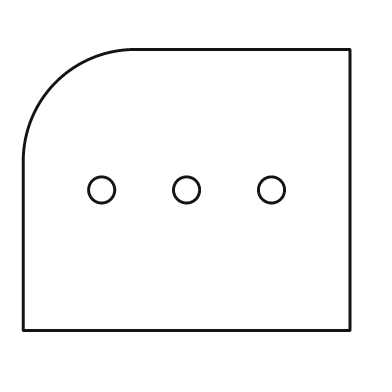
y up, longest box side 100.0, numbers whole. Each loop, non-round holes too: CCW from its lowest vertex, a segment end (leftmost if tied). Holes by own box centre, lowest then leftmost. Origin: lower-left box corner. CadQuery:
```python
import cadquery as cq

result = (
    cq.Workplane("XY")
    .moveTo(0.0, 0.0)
    .lineTo(100.0, 0.0)
    .lineTo(100.0, 86.0)
    .lineTo(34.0, 86.0)
    .threePointArc((10.0, 76.0), (0.0, 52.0))
    .close()
    .moveTo(24.0, 43.0)
    .circle(4.0)
    .moveTo(50.0, 43.0)
    .circle(4.0)
    .moveTo(76.0, 43.0)
    .circle(4.0)
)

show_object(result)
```